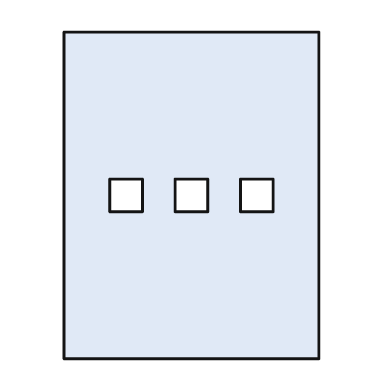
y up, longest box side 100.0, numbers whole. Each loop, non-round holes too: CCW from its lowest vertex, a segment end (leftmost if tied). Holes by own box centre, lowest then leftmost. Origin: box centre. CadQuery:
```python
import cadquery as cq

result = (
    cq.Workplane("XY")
    .moveTo(-39.0, -50.0)
    .lineTo(39.0, -50.0)
    .lineTo(39.0, 50.0)
    .lineTo(-39.0, 50.0)
    .close()
    .moveTo(-25.0, -5.0)
    .lineTo(-15.0, -5.0)
    .lineTo(-15.0, 5.0)
    .lineTo(-25.0, 5.0)
    .close()
    .moveTo(-5.0, -5.0)
    .lineTo(5.0, -5.0)
    .lineTo(5.0, 5.0)
    .lineTo(-5.0, 5.0)
    .close()
    .moveTo(15.0, -5.0)
    .lineTo(25.0, -5.0)
    .lineTo(25.0, 5.0)
    .lineTo(15.0, 5.0)
    .close()
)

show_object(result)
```